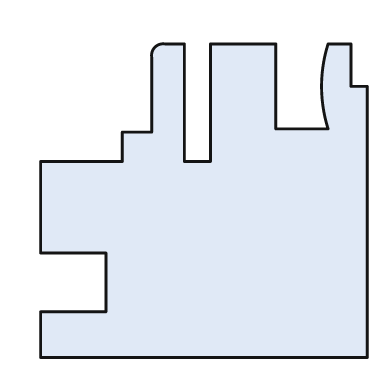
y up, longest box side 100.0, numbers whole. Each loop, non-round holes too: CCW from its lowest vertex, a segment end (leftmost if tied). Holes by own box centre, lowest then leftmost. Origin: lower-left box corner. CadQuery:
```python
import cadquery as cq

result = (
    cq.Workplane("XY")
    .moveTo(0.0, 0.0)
    .lineTo(100.0, 0.0)
    .lineTo(100.0, 83.0)
    .lineTo(95.0, 83.0)
    .lineTo(95.0, 96.0)
    .lineTo(88.0, 96.0)
    .threePointArc((86.0, 83.0), (88.0, 70.0))
    .lineTo(72.0, 70.0)
    .lineTo(72.0, 96.0)
    .lineTo(52.0, 96.0)
    .lineTo(52.0, 60.0)
    .lineTo(44.0, 60.0)
    .lineTo(44.0, 96.0)
    .lineTo(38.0, 96.0)
    .threePointArc((35.0, 95.0), (34.0, 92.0))
    .lineTo(34.0, 69.0)
    .lineTo(25.0, 69.0)
    .lineTo(25.0, 60.0)
    .lineTo(0.0, 60.0)
    .lineTo(0.0, 32.0)
    .lineTo(20.0, 32.0)
    .lineTo(20.0, 14.0)
    .lineTo(0.0, 14.0)
    .close()
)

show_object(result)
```